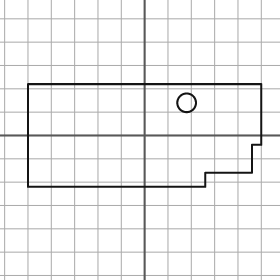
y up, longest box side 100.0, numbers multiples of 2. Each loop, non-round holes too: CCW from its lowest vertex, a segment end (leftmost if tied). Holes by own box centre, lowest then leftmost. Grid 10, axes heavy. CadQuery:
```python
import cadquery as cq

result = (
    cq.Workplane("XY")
    .moveTo(-50.0, -22.0)
    .lineTo(26.0, -22.0)
    .lineTo(26.0, -16.0)
    .lineTo(46.0, -16.0)
    .lineTo(46.0, -4.0)
    .lineTo(50.0, -4.0)
    .lineTo(50.0, 22.0)
    .lineTo(-50.0, 22.0)
    .close()
    .moveTo(18.0, 14.0)
    .circle(4.0)
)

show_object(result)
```